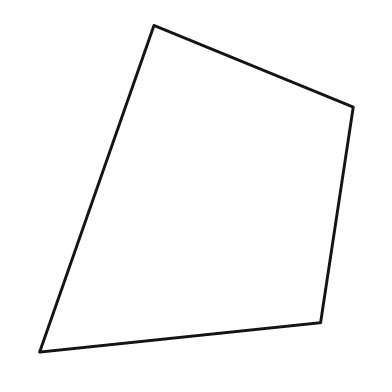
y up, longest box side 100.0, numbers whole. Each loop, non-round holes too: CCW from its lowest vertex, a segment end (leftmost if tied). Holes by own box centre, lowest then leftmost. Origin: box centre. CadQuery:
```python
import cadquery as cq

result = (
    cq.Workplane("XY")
    .moveTo(-48.0, -50.0)
    .lineTo(38.0, -41.0)
    .lineTo(48.0, 25.0)
    .lineTo(-13.0, 50.0)
    .close()
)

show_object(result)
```